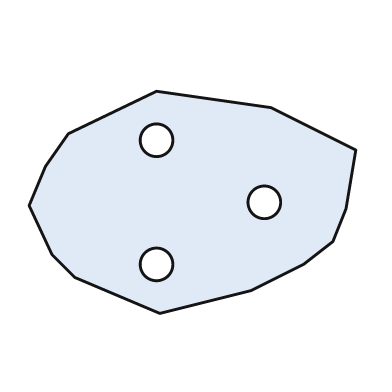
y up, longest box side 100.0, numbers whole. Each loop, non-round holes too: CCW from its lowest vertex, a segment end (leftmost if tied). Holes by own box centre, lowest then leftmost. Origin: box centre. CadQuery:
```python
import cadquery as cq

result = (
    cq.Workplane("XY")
    .moveTo(-10.0, -34.0)
    .lineTo(18.0, -27.0)
    .lineTo(34.0, -19.0)
    .lineTo(43.0, -12.0)
    .lineTo(47.0, -2.0)
    .lineTo(50.0, 16.0)
    .lineTo(24.0, 29.0)
    .lineTo(-11.0, 34.0)
    .lineTo(-38.0, 21.0)
    .lineTo(-45.0, 11.0)
    .lineTo(-50.0, -1.0)
    .lineTo(-43.0, -16.0)
    .lineTo(-36.0, -23.0)
    .close()
    .moveTo(-11.0, -19.0)
    .circle(5.0)
    .moveTo(22.0, 0.0)
    .circle(5.0)
    .moveTo(-11.0, 19.0)
    .circle(5.0)
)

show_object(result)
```